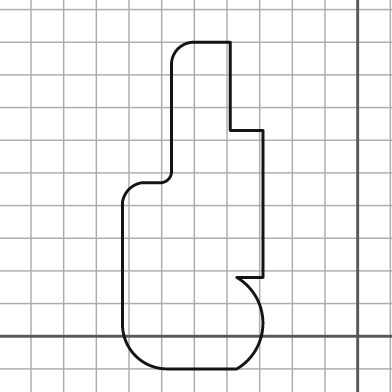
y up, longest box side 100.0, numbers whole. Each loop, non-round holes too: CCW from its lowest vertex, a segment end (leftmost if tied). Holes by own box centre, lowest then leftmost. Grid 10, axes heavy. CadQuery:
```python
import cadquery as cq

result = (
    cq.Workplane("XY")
    .moveTo(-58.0, -10.0)
    .lineTo(-37.0, -10.0)
    .threePointArc((-29.0, 4.0), (-37.0, 18.0))
    .lineTo(-29.0, 18.0)
    .lineTo(-29.0, 63.0)
    .lineTo(-39.0, 63.0)
    .lineTo(-39.0, 90.0)
    .lineTo(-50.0, 90.0)
    .threePointArc((-55.0, 88.0), (-57.0, 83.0))
    .lineTo(-57.0, 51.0)
    .threePointArc((-58.0, 48.0), (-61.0, 47.0))
    .lineTo(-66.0, 47.0)
    .threePointArc((-70.0, 45.0), (-72.0, 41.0))
    .lineTo(-72.0, 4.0)
    .threePointArc((-68.0, -6.0), (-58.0, -10.0))
    .close()
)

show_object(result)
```